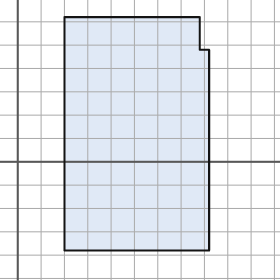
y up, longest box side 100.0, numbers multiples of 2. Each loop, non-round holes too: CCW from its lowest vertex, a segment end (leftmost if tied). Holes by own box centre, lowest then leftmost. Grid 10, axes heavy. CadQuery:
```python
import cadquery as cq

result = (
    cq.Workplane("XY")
    .moveTo(20.0, -38.0)
    .lineTo(82.0, -38.0)
    .lineTo(82.0, 48.0)
    .lineTo(78.0, 48.0)
    .lineTo(78.0, 62.0)
    .lineTo(20.0, 62.0)
    .close()
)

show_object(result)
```